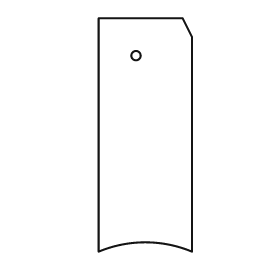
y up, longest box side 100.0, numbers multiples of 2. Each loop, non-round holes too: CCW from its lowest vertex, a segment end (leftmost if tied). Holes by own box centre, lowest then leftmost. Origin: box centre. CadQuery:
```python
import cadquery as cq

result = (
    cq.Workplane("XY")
    .moveTo(-20.0, -50.0)
    .threePointArc((0.0, -46.0), (20.0, -50.0))
    .lineTo(20.0, 42.0)
    .lineTo(16.0, 50.0)
    .lineTo(-20.0, 50.0)
    .close()
    .moveTo(-4.0, 34.0)
    .circle(2.0)
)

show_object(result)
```